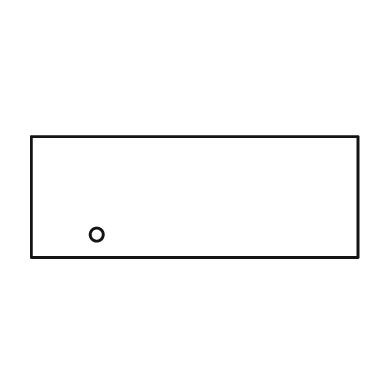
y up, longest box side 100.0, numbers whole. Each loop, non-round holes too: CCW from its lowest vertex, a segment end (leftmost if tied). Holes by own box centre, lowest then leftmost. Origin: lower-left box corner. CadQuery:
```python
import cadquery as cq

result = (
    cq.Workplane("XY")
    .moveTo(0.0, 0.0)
    .lineTo(100.0, 0.0)
    .lineTo(100.0, 37.0)
    .lineTo(0.0, 37.0)
    .close()
    .moveTo(20.0, 7.0)
    .circle(2.0)
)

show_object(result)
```